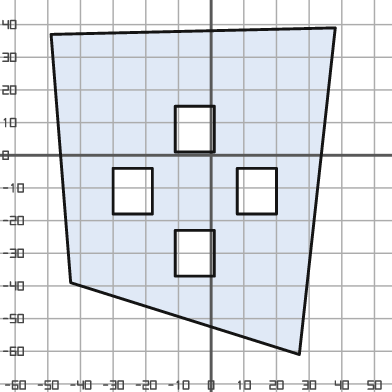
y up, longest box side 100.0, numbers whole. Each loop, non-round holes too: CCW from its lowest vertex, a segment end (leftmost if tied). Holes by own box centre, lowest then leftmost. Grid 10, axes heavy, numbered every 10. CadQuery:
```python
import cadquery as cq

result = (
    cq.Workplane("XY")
    .moveTo(27.0, -61.0)
    .lineTo(38.0, 39.0)
    .lineTo(-49.0, 37.0)
    .lineTo(-43.0, -39.0)
    .close()
    .moveTo(-11.0, -37.0)
    .lineTo(1.0, -37.0)
    .lineTo(1.0, -23.0)
    .lineTo(-11.0, -23.0)
    .close()
    .moveTo(-30.0, -18.0)
    .lineTo(-18.0, -18.0)
    .lineTo(-18.0, -4.0)
    .lineTo(-30.0, -4.0)
    .close()
    .moveTo(8.0, -18.0)
    .lineTo(20.0, -18.0)
    .lineTo(20.0, -4.0)
    .lineTo(8.0, -4.0)
    .close()
    .moveTo(-11.0, 1.0)
    .lineTo(1.0, 1.0)
    .lineTo(1.0, 15.0)
    .lineTo(-11.0, 15.0)
    .close()
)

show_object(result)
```